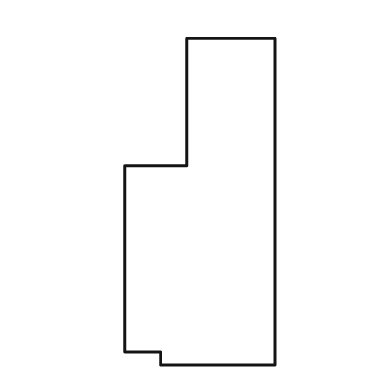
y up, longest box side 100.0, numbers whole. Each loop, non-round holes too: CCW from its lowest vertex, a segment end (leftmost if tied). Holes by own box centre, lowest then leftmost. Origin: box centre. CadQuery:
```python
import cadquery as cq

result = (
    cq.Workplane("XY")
    .moveTo(-12.0, -50.0)
    .lineTo(23.0, -50.0)
    .lineTo(23.0, 50.0)
    .lineTo(-4.0, 50.0)
    .lineTo(-4.0, 11.0)
    .lineTo(-23.0, 11.0)
    .lineTo(-23.0, -46.0)
    .lineTo(-12.0, -46.0)
    .close()
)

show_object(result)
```